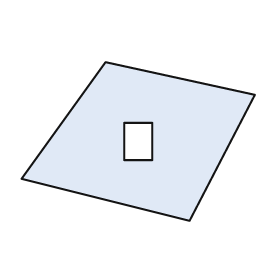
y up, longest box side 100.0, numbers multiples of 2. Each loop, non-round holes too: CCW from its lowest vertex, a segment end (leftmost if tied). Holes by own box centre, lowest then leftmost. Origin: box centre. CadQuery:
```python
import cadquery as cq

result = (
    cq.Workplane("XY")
    .moveTo(22.0, -34.0)
    .lineTo(50.0, 20.0)
    .lineTo(-14.0, 34.0)
    .lineTo(-50.0, -16.0)
    .close()
    .moveTo(-6.0, -8.0)
    .lineTo(6.0, -8.0)
    .lineTo(6.0, 8.0)
    .lineTo(-6.0, 8.0)
    .close()
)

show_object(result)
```